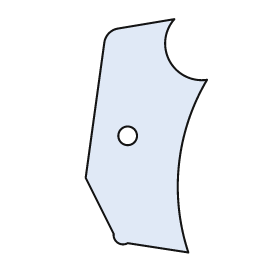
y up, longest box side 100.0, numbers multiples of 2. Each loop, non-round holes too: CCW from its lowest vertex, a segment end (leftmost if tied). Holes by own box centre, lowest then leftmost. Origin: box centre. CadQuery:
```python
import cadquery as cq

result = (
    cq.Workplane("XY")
    .moveTo(18.0, -50.0)
    .threePointArc((14.0, -12.0), (26.0, 24.0))
    .threePointArc((10.0, 32.0), (12.0, 50.0))
    .lineTo(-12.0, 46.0)
    .threePointArc((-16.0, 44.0), (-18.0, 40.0))
    .lineTo(-26.0, -18.0)
    .lineTo(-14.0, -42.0)
    .threePointArc((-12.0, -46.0), (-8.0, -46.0))
    .close()
    .moveTo(-8.0, 0.0)
    .circle(4.0)
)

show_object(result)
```